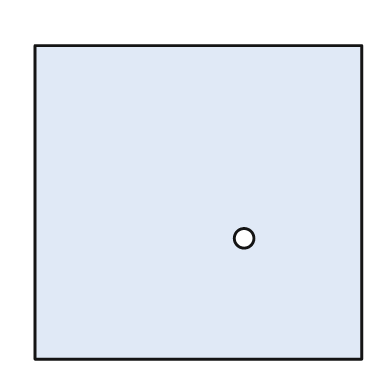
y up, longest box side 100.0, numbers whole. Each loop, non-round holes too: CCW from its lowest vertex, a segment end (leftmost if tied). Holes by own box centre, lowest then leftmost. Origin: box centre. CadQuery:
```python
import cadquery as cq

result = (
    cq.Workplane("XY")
    .moveTo(-50.0, -48.0)
    .lineTo(50.0, -48.0)
    .lineTo(50.0, 48.0)
    .lineTo(-50.0, 48.0)
    .close()
    .moveTo(14.0, -11.0)
    .circle(3.0)
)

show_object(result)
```